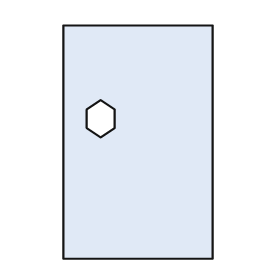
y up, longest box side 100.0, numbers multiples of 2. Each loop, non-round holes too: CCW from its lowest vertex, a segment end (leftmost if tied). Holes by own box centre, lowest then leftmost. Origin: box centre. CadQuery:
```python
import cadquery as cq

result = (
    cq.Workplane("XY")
    .moveTo(-32.0, -50.0)
    .lineTo(32.0, -50.0)
    .lineTo(32.0, 50.0)
    .lineTo(-32.0, 50.0)
    .close()
    .moveTo(-16.0, 2.0)
    .lineTo(-10.0, 6.0)
    .lineTo(-10.0, 14.0)
    .lineTo(-16.0, 18.0)
    .lineTo(-22.0, 14.0)
    .lineTo(-22.0, 6.0)
    .close()
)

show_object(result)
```